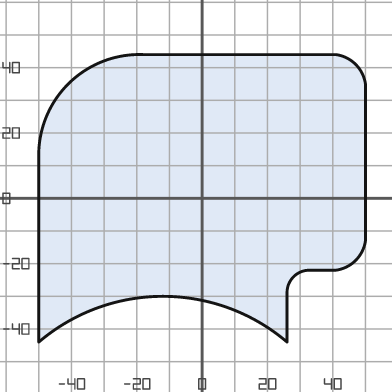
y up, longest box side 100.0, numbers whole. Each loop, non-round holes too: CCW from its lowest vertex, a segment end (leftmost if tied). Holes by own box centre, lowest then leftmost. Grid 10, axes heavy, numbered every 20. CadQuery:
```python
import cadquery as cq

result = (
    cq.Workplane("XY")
    .moveTo(-50.0, -44.0)
    .threePointArc((-12.0, -30.0), (26.0, -44.0))
    .lineTo(26.0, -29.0)
    .threePointArc((28.0, -24.0), (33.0, -22.0))
    .lineTo(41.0, -22.0)
    .threePointArc((47.0, -19.0), (50.0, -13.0))
    .lineTo(50.0, 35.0)
    .threePointArc((47.0, 41.0), (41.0, 44.0))
    .lineTo(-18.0, 44.0)
    .threePointArc((-41.0, 35.0), (-50.0, 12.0))
    .close()
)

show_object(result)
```